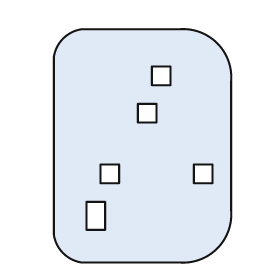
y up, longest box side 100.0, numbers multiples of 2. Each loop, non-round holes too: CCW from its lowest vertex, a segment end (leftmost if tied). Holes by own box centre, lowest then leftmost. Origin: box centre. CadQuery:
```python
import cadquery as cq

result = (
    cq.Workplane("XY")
    .moveTo(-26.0, -50.0)
    .lineTo(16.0, -50.0)
    .threePointArc((32.0, -44.0), (38.0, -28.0))
    .lineTo(38.0, 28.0)
    .threePointArc((32.0, 44.0), (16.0, 50.0))
    .lineTo(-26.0, 50.0)
    .threePointArc((-34.0, 46.0), (-38.0, 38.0))
    .lineTo(-38.0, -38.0)
    .threePointArc((-34.0, -46.0), (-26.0, -50.0))
    .close()
    .moveTo(-24.0, -36.0)
    .lineTo(-16.0, -36.0)
    .lineTo(-16.0, -24.0)
    .lineTo(-24.0, -24.0)
    .close()
    .moveTo(-18.0, -16.0)
    .lineTo(-10.0, -16.0)
    .lineTo(-10.0, -8.0)
    .lineTo(-18.0, -8.0)
    .close()
    .moveTo(22.0, -16.0)
    .lineTo(30.0, -16.0)
    .lineTo(30.0, -8.0)
    .lineTo(22.0, -8.0)
    .close()
    .moveTo(-2.0, 10.0)
    .lineTo(6.0, 10.0)
    .lineTo(6.0, 18.0)
    .lineTo(-2.0, 18.0)
    .close()
    .moveTo(4.0, 26.0)
    .lineTo(12.0, 26.0)
    .lineTo(12.0, 34.0)
    .lineTo(4.0, 34.0)
    .close()
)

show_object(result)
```